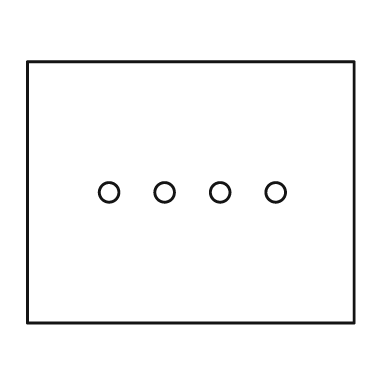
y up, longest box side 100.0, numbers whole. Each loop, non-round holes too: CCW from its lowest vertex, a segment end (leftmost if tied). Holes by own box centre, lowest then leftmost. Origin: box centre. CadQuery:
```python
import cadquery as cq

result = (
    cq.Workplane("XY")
    .moveTo(-50.0, -40.0)
    .lineTo(50.0, -40.0)
    .lineTo(50.0, 40.0)
    .lineTo(-50.0, 40.0)
    .close()
    .moveTo(-25.0, 0.0)
    .circle(3.0)
    .moveTo(-8.0, 0.0)
    .circle(3.0)
    .moveTo(9.0, 0.0)
    .circle(3.0)
    .moveTo(26.0, 0.0)
    .circle(3.0)
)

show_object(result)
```